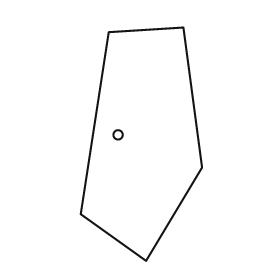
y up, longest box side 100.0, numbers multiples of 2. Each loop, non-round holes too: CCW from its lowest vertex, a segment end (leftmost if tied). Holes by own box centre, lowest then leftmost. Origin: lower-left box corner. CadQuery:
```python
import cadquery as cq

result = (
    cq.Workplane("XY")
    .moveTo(28.0, 0.0)
    .lineTo(52.0, 40.0)
    .lineTo(44.0, 100.0)
    .lineTo(12.0, 98.0)
    .lineTo(0.0, 20.0)
    .close()
    .moveTo(16.0, 54.0)
    .circle(2.0)
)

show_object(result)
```